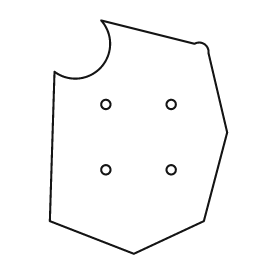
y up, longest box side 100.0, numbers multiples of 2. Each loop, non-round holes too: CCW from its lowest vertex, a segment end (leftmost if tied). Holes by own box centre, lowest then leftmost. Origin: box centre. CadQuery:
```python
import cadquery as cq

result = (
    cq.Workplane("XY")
    .moveTo(-2.0, -50.0)
    .lineTo(28.0, -36.0)
    .lineTo(38.0, 2.0)
    .lineTo(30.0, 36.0)
    .threePointArc((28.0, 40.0), (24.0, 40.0))
    .lineTo(-16.0, 50.0)
    .threePointArc((-16.0, 30.0), (-36.0, 28.0))
    .lineTo(-38.0, -36.0)
    .close()
    .moveTo(-14.0, -14.0)
    .circle(2.0)
    .moveTo(14.0, -14.0)
    .circle(2.0)
    .moveTo(-14.0, 14.0)
    .circle(2.0)
    .moveTo(14.0, 14.0)
    .circle(2.0)
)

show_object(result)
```